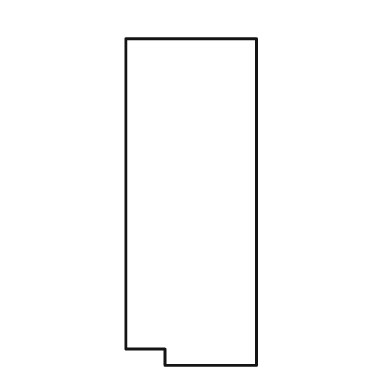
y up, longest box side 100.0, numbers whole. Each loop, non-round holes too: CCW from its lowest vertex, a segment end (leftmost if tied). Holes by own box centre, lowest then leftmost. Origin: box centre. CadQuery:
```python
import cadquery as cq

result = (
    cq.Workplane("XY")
    .moveTo(-8.0, -50.0)
    .lineTo(20.0, -50.0)
    .lineTo(20.0, 50.0)
    .lineTo(-20.0, 50.0)
    .lineTo(-20.0, -45.0)
    .lineTo(-8.0, -45.0)
    .close()
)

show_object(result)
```